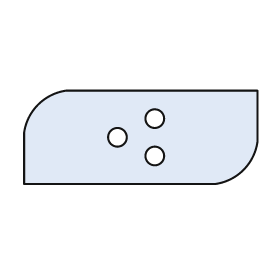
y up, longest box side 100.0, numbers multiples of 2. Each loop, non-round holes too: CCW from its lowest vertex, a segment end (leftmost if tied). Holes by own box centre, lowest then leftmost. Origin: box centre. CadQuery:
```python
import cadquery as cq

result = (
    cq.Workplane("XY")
    .moveTo(-50.0, -20.0)
    .lineTo(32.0, -20.0)
    .threePointArc((44.0, -14.0), (50.0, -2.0))
    .lineTo(50.0, 20.0)
    .lineTo(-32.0, 20.0)
    .threePointArc((-44.0, 14.0), (-50.0, 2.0))
    .close()
    .moveTo(6.0, -8.0)
    .circle(4.0)
    .moveTo(-10.0, 0.0)
    .circle(4.0)
    .moveTo(6.0, 8.0)
    .circle(4.0)
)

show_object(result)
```